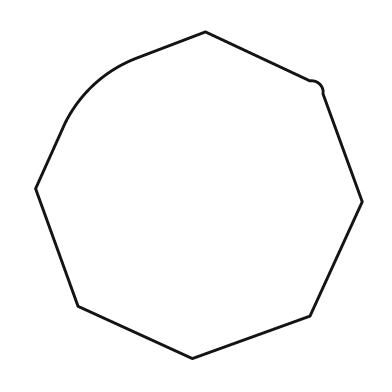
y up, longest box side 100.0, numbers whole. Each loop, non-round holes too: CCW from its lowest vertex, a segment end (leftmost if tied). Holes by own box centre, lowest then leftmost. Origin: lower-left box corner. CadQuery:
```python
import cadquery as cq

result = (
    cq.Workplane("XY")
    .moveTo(48.0, 0.0)
    .lineTo(84.0, 13.0)
    .lineTo(100.0, 48.0)
    .lineTo(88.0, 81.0)
    .threePointArc((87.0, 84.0), (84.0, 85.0))
    .lineTo(52.0, 100.0)
    .lineTo(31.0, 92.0)
    .threePointArc((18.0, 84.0), (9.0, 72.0))
    .lineTo(0.0, 52.0)
    .lineTo(13.0, 16.0)
    .close()
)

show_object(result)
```